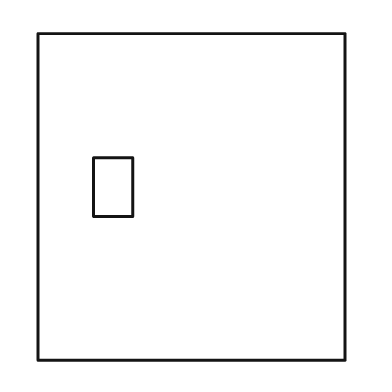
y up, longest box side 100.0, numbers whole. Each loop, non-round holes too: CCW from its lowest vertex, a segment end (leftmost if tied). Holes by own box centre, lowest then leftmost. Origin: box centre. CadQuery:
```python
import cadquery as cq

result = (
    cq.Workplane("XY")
    .moveTo(-47.0, -50.0)
    .lineTo(47.0, -50.0)
    .lineTo(47.0, 50.0)
    .lineTo(-47.0, 50.0)
    .close()
    .moveTo(-30.0, -6.0)
    .lineTo(-18.0, -6.0)
    .lineTo(-18.0, 12.0)
    .lineTo(-30.0, 12.0)
    .close()
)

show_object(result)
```